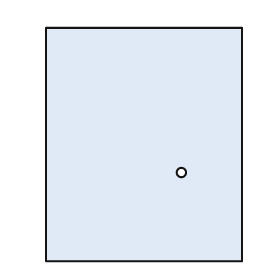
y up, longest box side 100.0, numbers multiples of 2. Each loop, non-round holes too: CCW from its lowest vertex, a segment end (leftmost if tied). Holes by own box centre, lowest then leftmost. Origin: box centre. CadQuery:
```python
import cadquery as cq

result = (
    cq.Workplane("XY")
    .moveTo(-42.0, -50.0)
    .lineTo(42.0, -50.0)
    .lineTo(42.0, 50.0)
    .lineTo(-42.0, 50.0)
    .close()
    .moveTo(16.0, -12.0)
    .circle(2.0)
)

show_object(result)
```